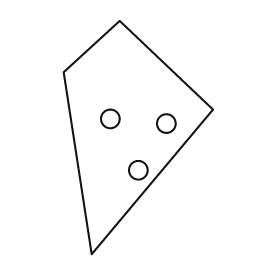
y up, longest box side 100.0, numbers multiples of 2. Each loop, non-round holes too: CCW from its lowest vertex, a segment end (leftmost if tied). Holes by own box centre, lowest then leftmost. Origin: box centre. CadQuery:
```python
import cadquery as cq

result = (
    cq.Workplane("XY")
    .moveTo(-20.0, -50.0)
    .lineTo(32.0, 12.0)
    .lineTo(-8.0, 50.0)
    .lineTo(-32.0, 28.0)
    .close()
    .moveTo(0.0, -14.0)
    .circle(4.0)
    .moveTo(12.0, 6.0)
    .circle(4.0)
    .moveTo(-12.0, 8.0)
    .circle(4.0)
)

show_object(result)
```